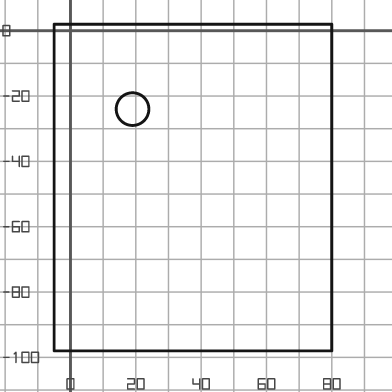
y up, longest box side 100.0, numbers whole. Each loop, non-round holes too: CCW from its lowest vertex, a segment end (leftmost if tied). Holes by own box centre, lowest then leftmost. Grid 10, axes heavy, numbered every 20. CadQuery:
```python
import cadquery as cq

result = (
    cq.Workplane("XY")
    .moveTo(-5.0, -98.0)
    .lineTo(80.0, -98.0)
    .lineTo(80.0, 2.0)
    .lineTo(-5.0, 2.0)
    .close()
    .moveTo(19.0, -24.0)
    .circle(5.0)
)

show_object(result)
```